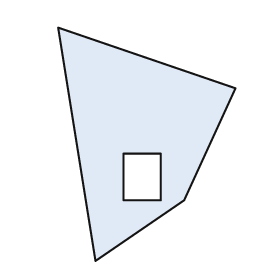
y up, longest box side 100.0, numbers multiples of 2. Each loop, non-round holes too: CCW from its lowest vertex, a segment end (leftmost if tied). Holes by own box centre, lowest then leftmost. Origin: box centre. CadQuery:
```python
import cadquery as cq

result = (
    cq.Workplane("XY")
    .moveTo(-22.0, -50.0)
    .lineTo(16.0, -24.0)
    .lineTo(38.0, 24.0)
    .lineTo(-38.0, 50.0)
    .close()
    .moveTo(-10.0, -24.0)
    .lineTo(6.0, -24.0)
    .lineTo(6.0, -4.0)
    .lineTo(-10.0, -4.0)
    .close()
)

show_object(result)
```